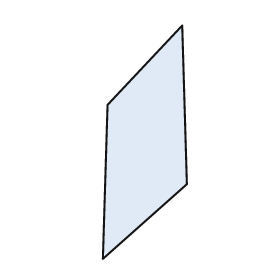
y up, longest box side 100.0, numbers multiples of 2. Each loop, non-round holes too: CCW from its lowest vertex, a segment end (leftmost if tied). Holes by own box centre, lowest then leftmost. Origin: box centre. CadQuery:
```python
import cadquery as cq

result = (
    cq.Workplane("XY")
    .moveTo(-18.0, -50.0)
    .lineTo(18.0, -18.0)
    .lineTo(16.0, 50.0)
    .lineTo(-16.0, 16.0)
    .close()
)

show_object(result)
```